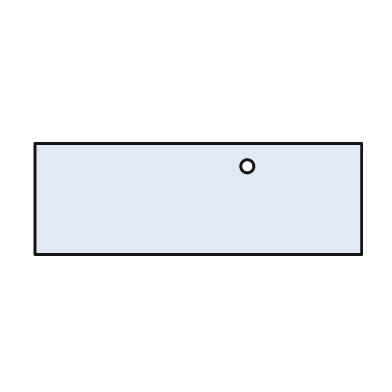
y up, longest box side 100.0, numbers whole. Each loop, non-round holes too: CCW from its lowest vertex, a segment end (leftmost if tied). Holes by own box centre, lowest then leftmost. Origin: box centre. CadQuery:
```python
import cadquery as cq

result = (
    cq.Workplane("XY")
    .moveTo(-50.0, -17.0)
    .lineTo(50.0, -17.0)
    .lineTo(50.0, 17.0)
    .lineTo(-50.0, 17.0)
    .close()
    .moveTo(15.0, 10.0)
    .circle(2.0)
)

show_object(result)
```